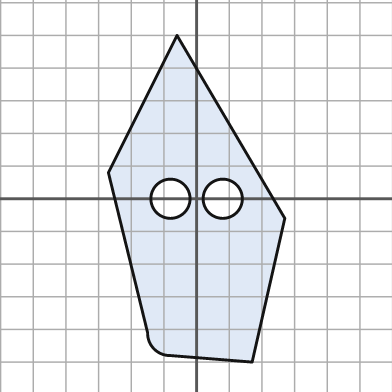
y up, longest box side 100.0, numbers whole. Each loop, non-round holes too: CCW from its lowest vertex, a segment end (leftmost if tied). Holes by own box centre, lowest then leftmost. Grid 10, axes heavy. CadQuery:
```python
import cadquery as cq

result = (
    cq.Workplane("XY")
    .moveTo(17.0, -50.0)
    .lineTo(27.0, -6.0)
    .lineTo(-6.0, 50.0)
    .lineTo(-27.0, 8.0)
    .lineTo(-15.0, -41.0)
    .threePointArc((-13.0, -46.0), (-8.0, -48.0))
    .close()
    .moveTo(-8.0, 0.0)
    .circle(6.0)
    .moveTo(8.0, 0.0)
    .circle(6.0)
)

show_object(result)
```